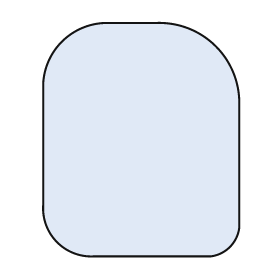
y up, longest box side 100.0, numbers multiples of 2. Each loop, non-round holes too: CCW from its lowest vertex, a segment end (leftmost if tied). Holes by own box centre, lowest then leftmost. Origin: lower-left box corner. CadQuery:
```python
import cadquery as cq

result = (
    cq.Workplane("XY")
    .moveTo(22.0, 0.0)
    .lineTo(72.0, 0.0)
    .threePointArc((80.0, 4.0), (84.0, 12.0))
    .lineTo(84.0, 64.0)
    .threePointArc((74.0, 90.0), (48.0, 100.0))
    .lineTo(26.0, 100.0)
    .threePointArc((8.0, 92.0), (0.0, 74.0))
    .lineTo(0.0, 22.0)
    .threePointArc((6.0, 6.0), (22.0, 0.0))
    .close()
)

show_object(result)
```